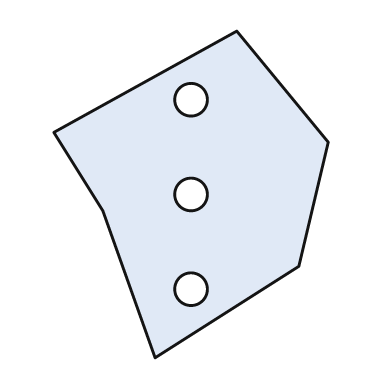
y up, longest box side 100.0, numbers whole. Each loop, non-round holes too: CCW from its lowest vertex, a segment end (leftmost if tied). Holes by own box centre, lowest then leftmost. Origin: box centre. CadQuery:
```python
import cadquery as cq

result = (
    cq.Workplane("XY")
    .moveTo(-11.0, -50.0)
    .lineTo(33.0, -22.0)
    .lineTo(42.0, 16.0)
    .lineTo(14.0, 50.0)
    .lineTo(-42.0, 19.0)
    .lineTo(-27.0, -5.0)
    .close()
    .moveTo(0.0, -29.0)
    .circle(5.0)
    .moveTo(0.0, 0.0)
    .circle(5.0)
    .moveTo(0.0, 29.0)
    .circle(5.0)
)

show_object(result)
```